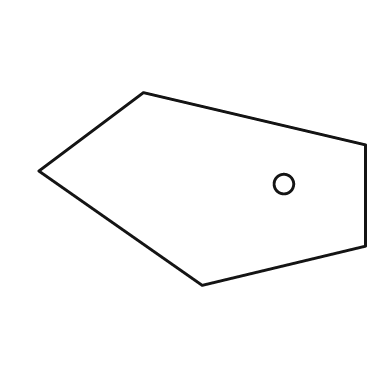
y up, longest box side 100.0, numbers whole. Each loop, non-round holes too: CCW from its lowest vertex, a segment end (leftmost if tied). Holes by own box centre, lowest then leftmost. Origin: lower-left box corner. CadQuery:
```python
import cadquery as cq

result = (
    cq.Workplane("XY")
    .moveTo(50.0, 0.0)
    .lineTo(100.0, 12.0)
    .lineTo(100.0, 43.0)
    .lineTo(32.0, 59.0)
    .lineTo(0.0, 35.0)
    .close()
    .moveTo(75.0, 31.0)
    .circle(3.0)
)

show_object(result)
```